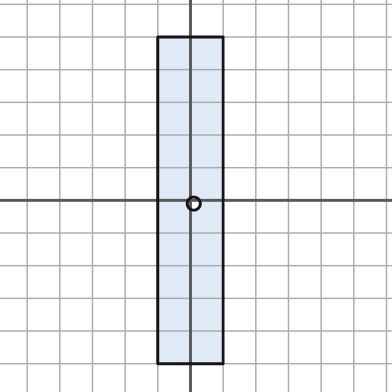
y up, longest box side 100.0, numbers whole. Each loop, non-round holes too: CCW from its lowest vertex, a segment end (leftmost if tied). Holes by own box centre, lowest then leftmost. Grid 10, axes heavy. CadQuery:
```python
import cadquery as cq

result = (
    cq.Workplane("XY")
    .moveTo(-10.0, -50.0)
    .lineTo(10.0, -50.0)
    .lineTo(10.0, 50.0)
    .lineTo(-10.0, 50.0)
    .close()
    .moveTo(1.0, -1.0)
    .circle(2.0)
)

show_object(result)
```